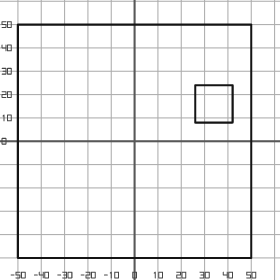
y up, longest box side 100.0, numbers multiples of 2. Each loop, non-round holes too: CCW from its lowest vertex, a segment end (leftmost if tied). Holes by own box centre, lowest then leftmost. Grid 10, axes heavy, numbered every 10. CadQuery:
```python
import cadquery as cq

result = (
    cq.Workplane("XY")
    .moveTo(-50.0, -50.0)
    .lineTo(50.0, -50.0)
    .lineTo(50.0, 50.0)
    .lineTo(-50.0, 50.0)
    .close()
    .moveTo(26.0, 8.0)
    .lineTo(42.0, 8.0)
    .lineTo(42.0, 24.0)
    .lineTo(26.0, 24.0)
    .close()
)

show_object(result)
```